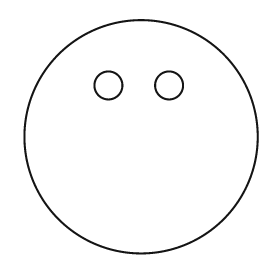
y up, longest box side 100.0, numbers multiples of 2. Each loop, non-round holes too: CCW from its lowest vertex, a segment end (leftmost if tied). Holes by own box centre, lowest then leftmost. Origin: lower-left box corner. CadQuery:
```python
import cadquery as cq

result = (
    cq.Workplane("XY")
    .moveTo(50.0, 50.0)
    .circle(50.0)
    .moveTo(36.0, 72.0)
    .circle(6.0)
    .moveTo(62.0, 72.0)
    .circle(6.0)
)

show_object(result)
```